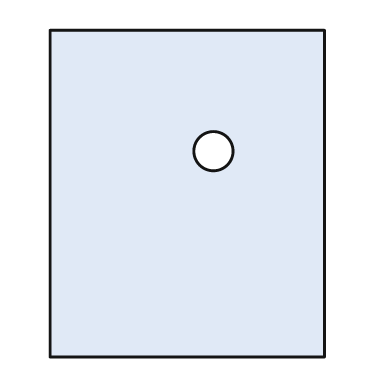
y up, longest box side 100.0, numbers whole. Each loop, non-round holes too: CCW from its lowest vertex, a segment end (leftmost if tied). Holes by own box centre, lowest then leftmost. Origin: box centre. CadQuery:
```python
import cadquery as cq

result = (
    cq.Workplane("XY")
    .moveTo(-42.0, -50.0)
    .lineTo(42.0, -50.0)
    .lineTo(42.0, 50.0)
    .lineTo(-42.0, 50.0)
    .close()
    .moveTo(8.0, 13.0)
    .circle(6.0)
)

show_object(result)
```